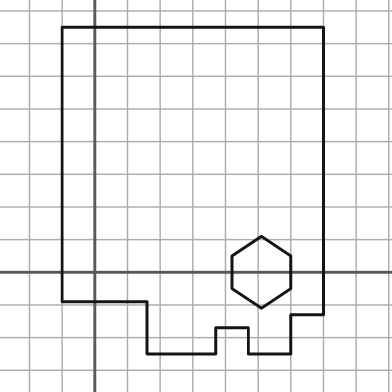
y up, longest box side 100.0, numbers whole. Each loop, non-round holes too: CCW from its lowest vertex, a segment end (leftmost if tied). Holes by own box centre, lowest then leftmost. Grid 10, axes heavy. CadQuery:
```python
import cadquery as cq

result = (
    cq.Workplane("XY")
    .moveTo(16.0, -25.0)
    .lineTo(37.0, -25.0)
    .lineTo(37.0, -17.0)
    .lineTo(47.0, -17.0)
    .lineTo(47.0, -25.0)
    .lineTo(60.0, -25.0)
    .lineTo(60.0, -13.0)
    .lineTo(70.0, -13.0)
    .lineTo(70.0, 75.0)
    .lineTo(-10.0, 75.0)
    .lineTo(-10.0, -9.0)
    .lineTo(16.0, -9.0)
    .close()
    .moveTo(51.0, -11.0)
    .lineTo(60.0, -5.0)
    .lineTo(60.0, 5.0)
    .lineTo(51.0, 11.0)
    .lineTo(42.0, 5.0)
    .lineTo(42.0, -5.0)
    .close()
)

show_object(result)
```